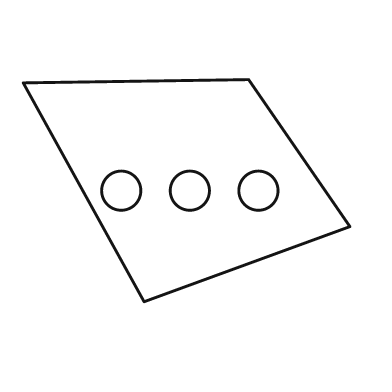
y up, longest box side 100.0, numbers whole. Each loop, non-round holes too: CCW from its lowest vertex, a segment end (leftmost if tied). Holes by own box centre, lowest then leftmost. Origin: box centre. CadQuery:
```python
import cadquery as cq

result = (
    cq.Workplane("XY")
    .moveTo(-13.0, -34.0)
    .lineTo(50.0, -11.0)
    .lineTo(19.0, 34.0)
    .lineTo(-50.0, 33.0)
    .close()
    .moveTo(-20.0, 0.0)
    .circle(6.0)
    .moveTo(1.0, 0.0)
    .circle(6.0)
    .moveTo(22.0, 0.0)
    .circle(6.0)
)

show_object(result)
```